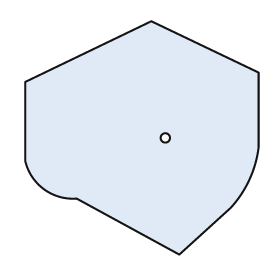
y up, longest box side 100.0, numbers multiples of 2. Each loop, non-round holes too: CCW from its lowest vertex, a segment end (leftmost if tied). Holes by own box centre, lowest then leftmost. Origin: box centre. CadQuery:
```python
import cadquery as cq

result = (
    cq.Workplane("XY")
    .moveTo(16.0, -50.0)
    .lineTo(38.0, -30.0)
    .threePointArc((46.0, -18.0), (50.0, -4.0))
    .lineTo(50.0, 28.0)
    .lineTo(4.0, 50.0)
    .lineTo(-50.0, 24.0)
    .lineTo(-50.0, -10.0)
    .threePointArc((-42.0, -22.0), (-28.0, -26.0))
    .close()
    .moveTo(10.0, 0.0)
    .circle(2.0)
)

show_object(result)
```